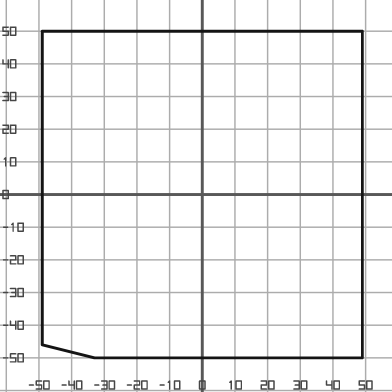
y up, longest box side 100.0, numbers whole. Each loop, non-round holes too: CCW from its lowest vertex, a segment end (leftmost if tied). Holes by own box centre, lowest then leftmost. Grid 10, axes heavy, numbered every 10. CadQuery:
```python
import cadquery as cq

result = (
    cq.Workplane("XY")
    .moveTo(-33.0, -50.0)
    .lineTo(49.0, -50.0)
    .lineTo(49.0, 50.0)
    .lineTo(-49.0, 50.0)
    .lineTo(-49.0, -46.0)
    .close()
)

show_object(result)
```